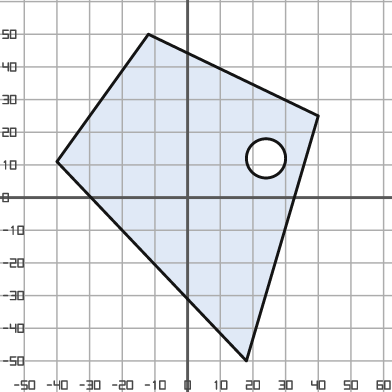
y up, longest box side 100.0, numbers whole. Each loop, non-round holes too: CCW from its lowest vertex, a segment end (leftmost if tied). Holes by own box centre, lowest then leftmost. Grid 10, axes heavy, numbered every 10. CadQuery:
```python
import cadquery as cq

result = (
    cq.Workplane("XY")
    .moveTo(18.0, -50.0)
    .lineTo(40.0, 25.0)
    .lineTo(-12.0, 50.0)
    .lineTo(-40.0, 11.0)
    .close()
    .moveTo(24.0, 12.0)
    .circle(6.0)
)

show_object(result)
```